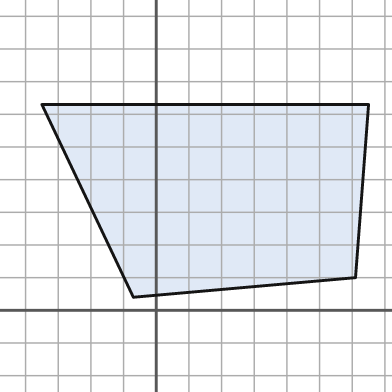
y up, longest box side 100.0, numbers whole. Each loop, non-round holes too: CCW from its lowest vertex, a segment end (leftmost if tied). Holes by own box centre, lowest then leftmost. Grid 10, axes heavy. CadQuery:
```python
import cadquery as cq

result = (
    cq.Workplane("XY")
    .moveTo(-7.0, 4.0)
    .lineTo(61.0, 10.0)
    .lineTo(65.0, 63.0)
    .lineTo(-35.0, 63.0)
    .close()
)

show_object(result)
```